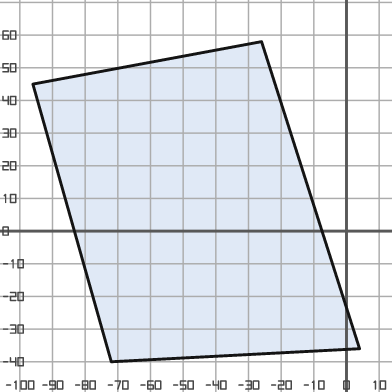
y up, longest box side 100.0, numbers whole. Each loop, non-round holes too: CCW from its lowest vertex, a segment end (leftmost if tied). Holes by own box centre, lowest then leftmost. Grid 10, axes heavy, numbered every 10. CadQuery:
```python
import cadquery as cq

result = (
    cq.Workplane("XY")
    .moveTo(-72.0, -40.0)
    .lineTo(4.0, -36.0)
    .lineTo(-26.0, 58.0)
    .lineTo(-96.0, 45.0)
    .close()
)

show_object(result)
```